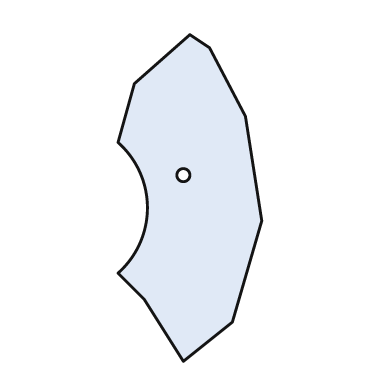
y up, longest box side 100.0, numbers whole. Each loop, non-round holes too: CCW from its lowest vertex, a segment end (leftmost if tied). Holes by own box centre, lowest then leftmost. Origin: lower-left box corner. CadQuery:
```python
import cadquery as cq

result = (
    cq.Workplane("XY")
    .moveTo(20.0, 0.0)
    .lineTo(35.0, 12.0)
    .lineTo(44.0, 43.0)
    .lineTo(39.0, 75.0)
    .lineTo(28.0, 96.0)
    .lineTo(22.0, 100.0)
    .lineTo(5.0, 85.0)
    .lineTo(0.0, 67.0)
    .threePointArc((9.0, 47.0), (0.0, 27.0))
    .lineTo(8.0, 19.0)
    .close()
    .moveTo(20.0, 57.0)
    .circle(2.0)
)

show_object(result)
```